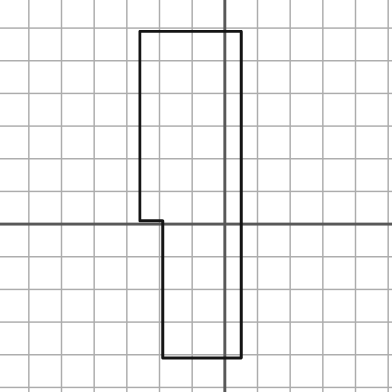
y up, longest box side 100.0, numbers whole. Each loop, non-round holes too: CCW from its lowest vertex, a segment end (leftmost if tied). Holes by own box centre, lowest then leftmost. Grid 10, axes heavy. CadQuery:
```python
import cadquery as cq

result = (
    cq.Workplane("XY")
    .moveTo(-19.0, -41.0)
    .lineTo(5.0, -41.0)
    .lineTo(5.0, 59.0)
    .lineTo(-26.0, 59.0)
    .lineTo(-26.0, 1.0)
    .lineTo(-19.0, 1.0)
    .close()
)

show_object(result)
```